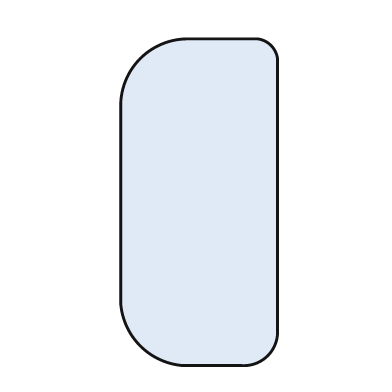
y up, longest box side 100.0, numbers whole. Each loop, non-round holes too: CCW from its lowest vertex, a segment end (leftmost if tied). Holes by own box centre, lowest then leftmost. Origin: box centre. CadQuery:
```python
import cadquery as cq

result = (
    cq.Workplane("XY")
    .moveTo(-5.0, -50.0)
    .lineTo(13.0, -50.0)
    .threePointArc((21.0, -47.0), (24.0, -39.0))
    .lineTo(24.0, 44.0)
    .threePointArc((22.0, 48.0), (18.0, 50.0))
    .lineTo(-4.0, 50.0)
    .threePointArc((-18.0, 44.0), (-24.0, 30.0))
    .lineTo(-24.0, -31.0)
    .threePointArc((-18.0, -44.0), (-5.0, -50.0))
    .close()
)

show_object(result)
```